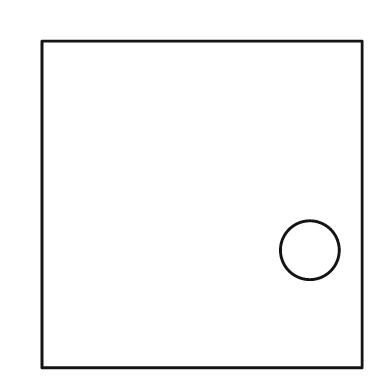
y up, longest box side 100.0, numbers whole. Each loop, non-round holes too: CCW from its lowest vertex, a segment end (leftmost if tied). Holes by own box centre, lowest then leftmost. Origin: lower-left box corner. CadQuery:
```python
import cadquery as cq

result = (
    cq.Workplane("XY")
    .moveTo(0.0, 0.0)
    .lineTo(98.0, 0.0)
    .lineTo(98.0, 100.0)
    .lineTo(0.0, 100.0)
    .close()
    .moveTo(82.0, 36.0)
    .circle(9.0)
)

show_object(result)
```